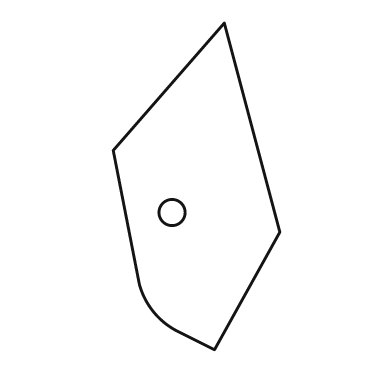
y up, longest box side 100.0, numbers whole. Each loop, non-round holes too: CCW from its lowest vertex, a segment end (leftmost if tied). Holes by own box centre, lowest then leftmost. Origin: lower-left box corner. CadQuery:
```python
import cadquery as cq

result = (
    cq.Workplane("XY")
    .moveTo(31.0, 0.0)
    .lineTo(51.0, 36.0)
    .lineTo(34.0, 100.0)
    .lineTo(0.0, 61.0)
    .lineTo(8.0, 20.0)
    .threePointArc((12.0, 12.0), (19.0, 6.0))
    .close()
    .moveTo(18.0, 42.0)
    .circle(4.0)
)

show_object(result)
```